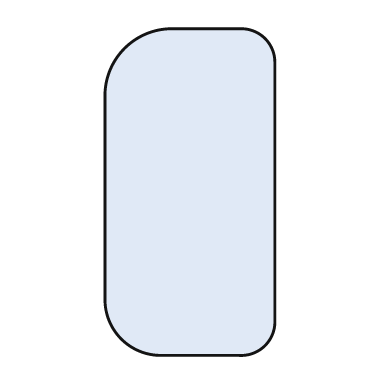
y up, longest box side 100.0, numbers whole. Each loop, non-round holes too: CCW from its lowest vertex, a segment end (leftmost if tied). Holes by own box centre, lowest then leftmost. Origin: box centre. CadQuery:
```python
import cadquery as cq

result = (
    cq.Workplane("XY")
    .moveTo(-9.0, -50.0)
    .lineTo(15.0, -50.0)
    .threePointArc((23.0, -47.0), (26.0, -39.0))
    .lineTo(26.0, 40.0)
    .threePointArc((23.0, 47.0), (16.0, 50.0))
    .lineTo(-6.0, 50.0)
    .threePointArc((-20.0, 44.0), (-26.0, 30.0))
    .lineTo(-26.0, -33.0)
    .threePointArc((-21.0, -45.0), (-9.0, -50.0))
    .close()
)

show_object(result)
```